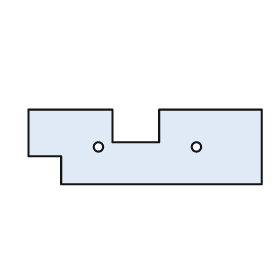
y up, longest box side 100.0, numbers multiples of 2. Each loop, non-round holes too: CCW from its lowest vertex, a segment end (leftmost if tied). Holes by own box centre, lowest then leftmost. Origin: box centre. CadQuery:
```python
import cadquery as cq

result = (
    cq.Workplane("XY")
    .moveTo(-36.0, -16.0)
    .lineTo(50.0, -16.0)
    .lineTo(50.0, 16.0)
    .lineTo(6.0, 16.0)
    .lineTo(6.0, 2.0)
    .lineTo(-14.0, 2.0)
    .lineTo(-14.0, 16.0)
    .lineTo(-50.0, 16.0)
    .lineTo(-50.0, -4.0)
    .lineTo(-36.0, -4.0)
    .close()
    .moveTo(-20.0, 0.0)
    .circle(2.0)
    .moveTo(22.0, 0.0)
    .circle(2.0)
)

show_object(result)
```